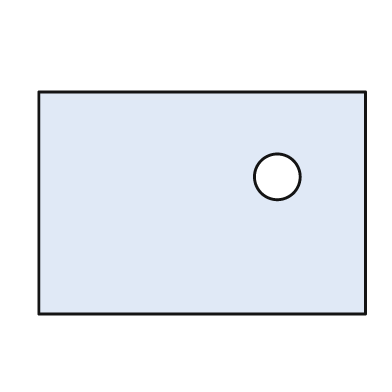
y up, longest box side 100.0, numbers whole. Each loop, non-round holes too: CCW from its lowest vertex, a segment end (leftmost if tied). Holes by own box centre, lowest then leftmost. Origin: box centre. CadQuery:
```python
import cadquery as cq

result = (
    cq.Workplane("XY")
    .moveTo(-50.0, -34.0)
    .lineTo(50.0, -34.0)
    .lineTo(50.0, 34.0)
    .lineTo(-50.0, 34.0)
    .close()
    .moveTo(23.0, 8.0)
    .circle(7.0)
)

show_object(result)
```